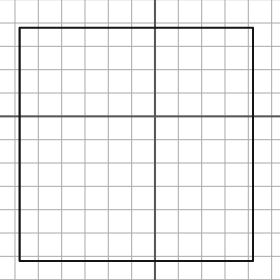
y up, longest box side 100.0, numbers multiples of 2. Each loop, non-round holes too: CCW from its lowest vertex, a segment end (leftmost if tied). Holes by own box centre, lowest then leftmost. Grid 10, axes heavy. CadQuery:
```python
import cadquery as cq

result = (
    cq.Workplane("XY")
    .moveTo(-58.0, -62.0)
    .lineTo(42.0, -62.0)
    .lineTo(42.0, 38.0)
    .lineTo(-58.0, 38.0)
    .close()
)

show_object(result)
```